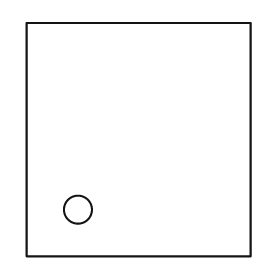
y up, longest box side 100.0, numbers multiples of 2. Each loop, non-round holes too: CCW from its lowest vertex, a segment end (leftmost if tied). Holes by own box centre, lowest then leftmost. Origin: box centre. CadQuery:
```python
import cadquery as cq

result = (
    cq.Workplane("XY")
    .moveTo(-48.0, -50.0)
    .lineTo(48.0, -50.0)
    .lineTo(48.0, 50.0)
    .lineTo(-48.0, 50.0)
    .close()
    .moveTo(-26.0, -30.0)
    .circle(6.0)
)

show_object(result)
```